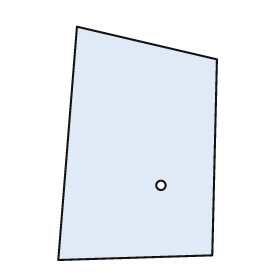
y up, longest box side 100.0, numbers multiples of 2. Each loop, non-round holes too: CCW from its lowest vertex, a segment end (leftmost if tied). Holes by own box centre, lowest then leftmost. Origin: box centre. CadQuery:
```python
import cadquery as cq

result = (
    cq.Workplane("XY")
    .moveTo(-34.0, -50.0)
    .lineTo(32.0, -48.0)
    .lineTo(34.0, 36.0)
    .lineTo(-26.0, 50.0)
    .close()
    .moveTo(10.0, -18.0)
    .circle(2.0)
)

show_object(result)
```